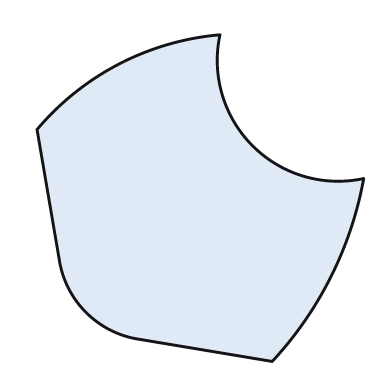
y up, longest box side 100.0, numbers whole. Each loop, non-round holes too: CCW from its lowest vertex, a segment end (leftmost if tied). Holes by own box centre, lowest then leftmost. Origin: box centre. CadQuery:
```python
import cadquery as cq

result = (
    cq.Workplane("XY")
    .moveTo(22.0, -50.0)
    .threePointArc((40.0, -24.0), (50.0, 6.0))
    .threePointArc((16.0, 16.0), (6.0, 50.0))
    .threePointArc((-25.0, 41.0), (-50.0, 21.0))
    .lineTo(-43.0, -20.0)
    .threePointArc((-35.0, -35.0), (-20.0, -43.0))
    .close()
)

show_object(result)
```